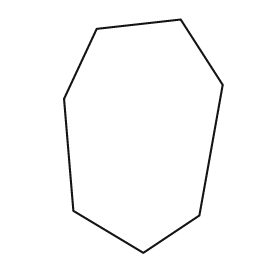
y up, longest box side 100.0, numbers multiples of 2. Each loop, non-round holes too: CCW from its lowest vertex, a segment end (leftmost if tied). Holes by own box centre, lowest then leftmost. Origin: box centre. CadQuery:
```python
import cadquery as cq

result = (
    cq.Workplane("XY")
    .moveTo(0.0, -50.0)
    .lineTo(24.0, -34.0)
    .lineTo(34.0, 22.0)
    .lineTo(16.0, 50.0)
    .lineTo(-20.0, 46.0)
    .lineTo(-34.0, 16.0)
    .lineTo(-30.0, -32.0)
    .close()
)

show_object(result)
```